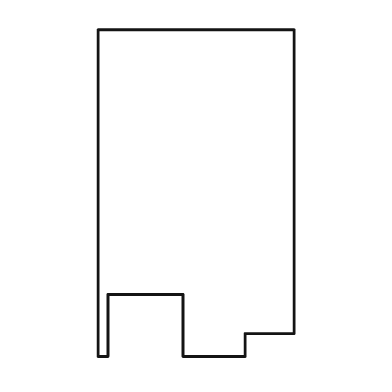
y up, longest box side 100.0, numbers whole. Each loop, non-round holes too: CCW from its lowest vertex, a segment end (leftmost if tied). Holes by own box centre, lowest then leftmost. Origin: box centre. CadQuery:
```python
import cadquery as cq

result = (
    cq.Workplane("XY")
    .moveTo(-30.0, -50.0)
    .lineTo(-27.0, -50.0)
    .lineTo(-27.0, -31.0)
    .lineTo(-4.0, -31.0)
    .lineTo(-4.0, -50.0)
    .lineTo(15.0, -50.0)
    .lineTo(15.0, -43.0)
    .lineTo(30.0, -43.0)
    .lineTo(30.0, 50.0)
    .lineTo(-30.0, 50.0)
    .close()
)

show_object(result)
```